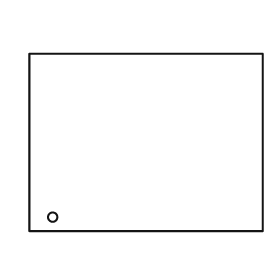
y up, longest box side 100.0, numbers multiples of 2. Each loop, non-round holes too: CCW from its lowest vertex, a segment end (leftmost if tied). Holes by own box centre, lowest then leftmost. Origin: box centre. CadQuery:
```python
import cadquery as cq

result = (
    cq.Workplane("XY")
    .moveTo(-50.0, -38.0)
    .lineTo(50.0, -38.0)
    .lineTo(50.0, 38.0)
    .lineTo(-50.0, 38.0)
    .close()
    .moveTo(-40.0, -32.0)
    .circle(2.0)
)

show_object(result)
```